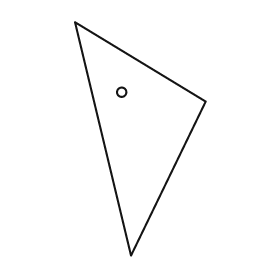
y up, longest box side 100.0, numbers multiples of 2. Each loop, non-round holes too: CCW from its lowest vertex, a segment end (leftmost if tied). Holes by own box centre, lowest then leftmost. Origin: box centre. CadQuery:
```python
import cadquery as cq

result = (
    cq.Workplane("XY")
    .moveTo(-4.0, -50.0)
    .lineTo(28.0, 16.0)
    .lineTo(-28.0, 50.0)
    .close()
    .moveTo(-8.0, 20.0)
    .circle(2.0)
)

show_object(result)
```